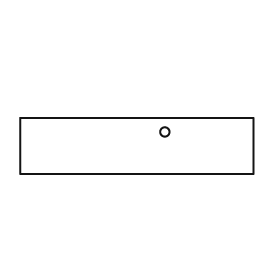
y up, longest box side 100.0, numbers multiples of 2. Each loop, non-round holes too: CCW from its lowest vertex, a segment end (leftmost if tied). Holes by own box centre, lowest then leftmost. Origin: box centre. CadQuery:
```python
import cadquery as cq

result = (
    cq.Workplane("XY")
    .moveTo(-50.0, -12.0)
    .lineTo(50.0, -12.0)
    .lineTo(50.0, 12.0)
    .lineTo(-50.0, 12.0)
    .close()
    .moveTo(12.0, 6.0)
    .circle(2.0)
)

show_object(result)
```